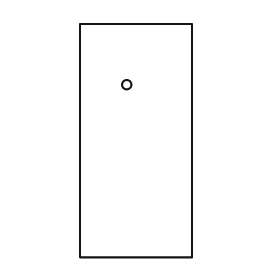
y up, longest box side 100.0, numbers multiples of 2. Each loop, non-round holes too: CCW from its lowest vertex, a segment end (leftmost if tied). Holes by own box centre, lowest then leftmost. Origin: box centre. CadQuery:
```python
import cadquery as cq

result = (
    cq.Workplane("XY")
    .moveTo(-24.0, -50.0)
    .lineTo(24.0, -50.0)
    .lineTo(24.0, 50.0)
    .lineTo(-24.0, 50.0)
    .close()
    .moveTo(-4.0, 24.0)
    .circle(2.0)
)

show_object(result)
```